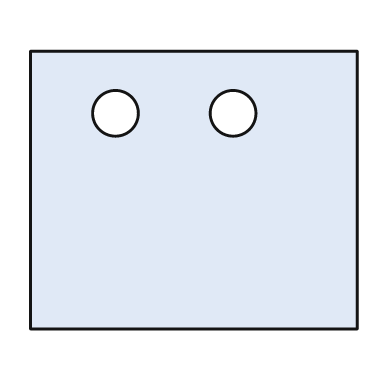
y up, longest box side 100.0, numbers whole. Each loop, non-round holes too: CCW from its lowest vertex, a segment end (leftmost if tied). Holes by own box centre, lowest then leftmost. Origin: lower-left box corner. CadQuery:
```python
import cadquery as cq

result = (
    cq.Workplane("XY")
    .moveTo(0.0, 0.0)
    .lineTo(100.0, 0.0)
    .lineTo(100.0, 85.0)
    .lineTo(0.0, 85.0)
    .close()
    .moveTo(26.0, 66.0)
    .circle(7.0)
    .moveTo(62.0, 66.0)
    .circle(7.0)
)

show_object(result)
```